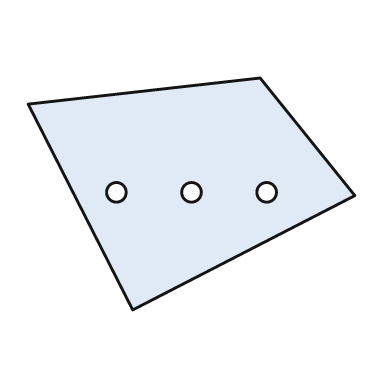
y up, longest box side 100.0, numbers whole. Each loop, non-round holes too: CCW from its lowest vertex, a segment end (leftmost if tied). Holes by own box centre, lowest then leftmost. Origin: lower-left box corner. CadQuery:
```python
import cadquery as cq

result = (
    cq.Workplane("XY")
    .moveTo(32.0, 0.0)
    .lineTo(100.0, 35.0)
    .lineTo(71.0, 71.0)
    .lineTo(0.0, 63.0)
    .close()
    .moveTo(27.0, 36.0)
    .circle(3.0)
    .moveTo(50.0, 36.0)
    .circle(3.0)
    .moveTo(73.0, 36.0)
    .circle(3.0)
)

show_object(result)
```